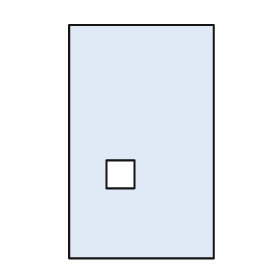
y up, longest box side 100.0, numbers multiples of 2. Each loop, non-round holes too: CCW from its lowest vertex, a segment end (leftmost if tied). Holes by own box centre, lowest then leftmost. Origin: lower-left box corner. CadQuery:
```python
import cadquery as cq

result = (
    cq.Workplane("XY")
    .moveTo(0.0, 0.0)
    .lineTo(62.0, 0.0)
    .lineTo(62.0, 100.0)
    .lineTo(0.0, 100.0)
    .close()
    .moveTo(16.0, 30.0)
    .lineTo(28.0, 30.0)
    .lineTo(28.0, 42.0)
    .lineTo(16.0, 42.0)
    .close()
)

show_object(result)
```